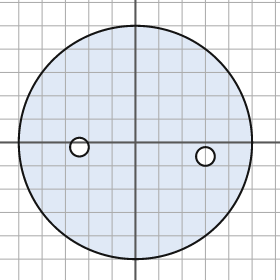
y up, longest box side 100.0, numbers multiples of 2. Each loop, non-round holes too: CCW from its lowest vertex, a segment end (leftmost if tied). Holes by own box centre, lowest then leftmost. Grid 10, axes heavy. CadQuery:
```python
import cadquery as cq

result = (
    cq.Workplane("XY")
    .moveTo(0.0, 0.0)
    .circle(50.0)
    .moveTo(30.0, -6.0)
    .circle(4.0)
    .moveTo(-24.0, -2.0)
    .circle(4.0)
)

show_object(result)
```